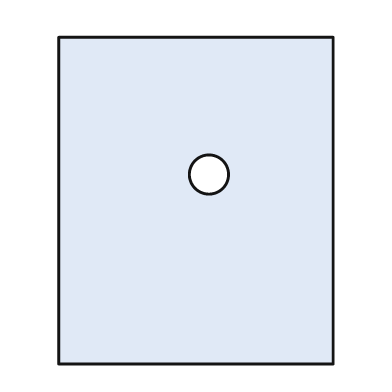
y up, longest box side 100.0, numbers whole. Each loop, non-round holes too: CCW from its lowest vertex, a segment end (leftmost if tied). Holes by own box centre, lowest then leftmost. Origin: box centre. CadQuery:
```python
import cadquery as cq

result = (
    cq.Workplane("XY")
    .moveTo(-42.0, -50.0)
    .lineTo(42.0, -50.0)
    .lineTo(42.0, 50.0)
    .lineTo(-42.0, 50.0)
    .close()
    .moveTo(4.0, 8.0)
    .circle(6.0)
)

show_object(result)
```